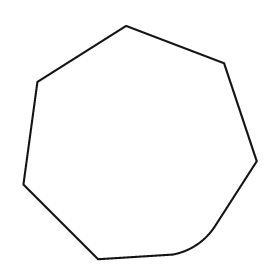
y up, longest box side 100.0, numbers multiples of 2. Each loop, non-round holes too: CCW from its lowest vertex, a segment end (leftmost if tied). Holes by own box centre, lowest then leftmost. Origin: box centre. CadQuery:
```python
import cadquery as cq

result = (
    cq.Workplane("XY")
    .moveTo(-18.0, -50.0)
    .lineTo(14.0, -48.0)
    .threePointArc((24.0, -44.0), (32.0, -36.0))
    .lineTo(50.0, -8.0)
    .lineTo(36.0, 34.0)
    .lineTo(-6.0, 50.0)
    .lineTo(-44.0, 26.0)
    .lineTo(-50.0, -18.0)
    .close()
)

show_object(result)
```